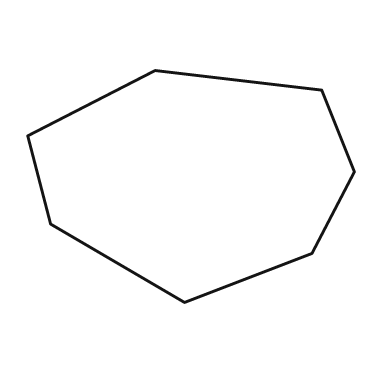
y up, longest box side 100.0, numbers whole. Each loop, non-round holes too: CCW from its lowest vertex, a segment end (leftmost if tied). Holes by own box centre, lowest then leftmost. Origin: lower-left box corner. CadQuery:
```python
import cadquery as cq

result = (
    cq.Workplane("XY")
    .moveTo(48.0, 0.0)
    .lineTo(87.0, 15.0)
    .lineTo(100.0, 40.0)
    .lineTo(90.0, 65.0)
    .lineTo(39.0, 71.0)
    .lineTo(0.0, 51.0)
    .lineTo(7.0, 24.0)
    .close()
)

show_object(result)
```